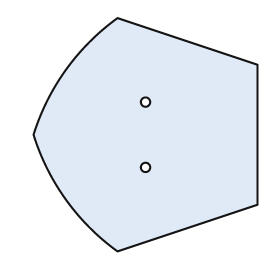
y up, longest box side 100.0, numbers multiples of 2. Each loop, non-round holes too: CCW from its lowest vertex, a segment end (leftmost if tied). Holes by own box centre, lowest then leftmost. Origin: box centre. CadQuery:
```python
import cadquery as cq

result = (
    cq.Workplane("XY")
    .moveTo(-12.0, -50.0)
    .lineTo(48.0, -30.0)
    .lineTo(48.0, 30.0)
    .lineTo(-12.0, 50.0)
    .threePointArc((-34.0, 28.0), (-48.0, 0.0))
    .threePointArc((-34.0, -28.0), (-12.0, -50.0))
    .close()
    .moveTo(0.0, -14.0)
    .circle(2.0)
    .moveTo(0.0, 14.0)
    .circle(2.0)
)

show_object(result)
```